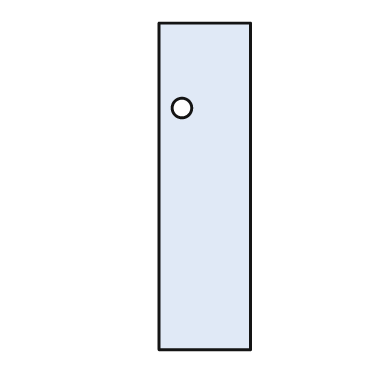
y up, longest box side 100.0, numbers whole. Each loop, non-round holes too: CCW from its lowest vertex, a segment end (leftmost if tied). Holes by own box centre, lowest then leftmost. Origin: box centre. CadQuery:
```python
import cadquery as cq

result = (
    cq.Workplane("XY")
    .moveTo(-14.0, -50.0)
    .lineTo(14.0, -50.0)
    .lineTo(14.0, 50.0)
    .lineTo(-14.0, 50.0)
    .close()
    .moveTo(-7.0, 24.0)
    .circle(3.0)
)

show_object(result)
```